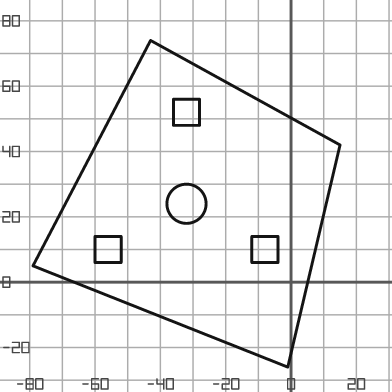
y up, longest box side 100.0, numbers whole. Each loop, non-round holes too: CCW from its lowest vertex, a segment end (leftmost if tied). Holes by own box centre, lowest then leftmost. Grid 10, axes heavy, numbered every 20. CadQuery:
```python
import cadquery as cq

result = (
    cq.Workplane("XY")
    .moveTo(-1.0, -26.0)
    .lineTo(15.0, 42.0)
    .lineTo(-43.0, 74.0)
    .lineTo(-79.0, 5.0)
    .close()
    .moveTo(-60.0, 6.0)
    .lineTo(-52.0, 6.0)
    .lineTo(-52.0, 14.0)
    .lineTo(-60.0, 14.0)
    .close()
    .moveTo(-12.0, 6.0)
    .lineTo(-4.0, 6.0)
    .lineTo(-4.0, 14.0)
    .lineTo(-12.0, 14.0)
    .close()
    .moveTo(-32.0, 24.0)
    .circle(6.0)
    .moveTo(-36.0, 48.0)
    .lineTo(-28.0, 48.0)
    .lineTo(-28.0, 56.0)
    .lineTo(-36.0, 56.0)
    .close()
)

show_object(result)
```